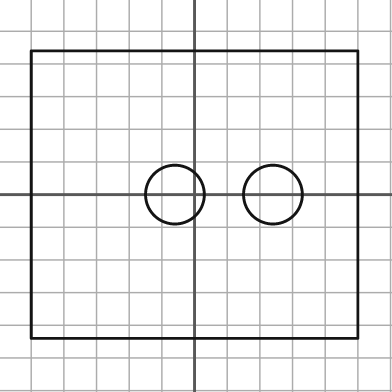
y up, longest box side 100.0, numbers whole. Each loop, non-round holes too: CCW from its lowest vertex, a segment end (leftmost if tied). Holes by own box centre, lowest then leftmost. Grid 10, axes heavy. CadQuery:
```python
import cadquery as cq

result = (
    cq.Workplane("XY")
    .moveTo(-50.0, -44.0)
    .lineTo(50.0, -44.0)
    .lineTo(50.0, 44.0)
    .lineTo(-50.0, 44.0)
    .close()
    .moveTo(-6.0, 0.0)
    .circle(9.0)
    .moveTo(24.0, 0.0)
    .circle(9.0)
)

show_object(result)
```